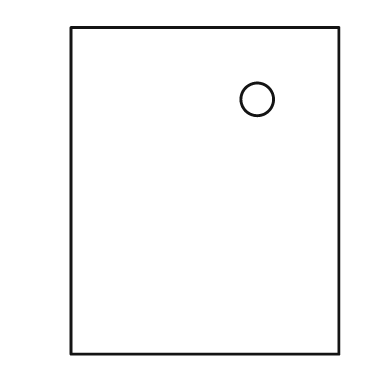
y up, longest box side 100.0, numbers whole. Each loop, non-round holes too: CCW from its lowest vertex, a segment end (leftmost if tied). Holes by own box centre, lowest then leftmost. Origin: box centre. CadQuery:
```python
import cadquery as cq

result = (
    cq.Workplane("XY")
    .moveTo(-41.0, -50.0)
    .lineTo(41.0, -50.0)
    .lineTo(41.0, 50.0)
    .lineTo(-41.0, 50.0)
    .close()
    .moveTo(16.0, 28.0)
    .circle(5.0)
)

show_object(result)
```